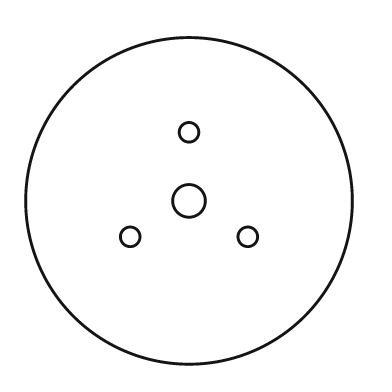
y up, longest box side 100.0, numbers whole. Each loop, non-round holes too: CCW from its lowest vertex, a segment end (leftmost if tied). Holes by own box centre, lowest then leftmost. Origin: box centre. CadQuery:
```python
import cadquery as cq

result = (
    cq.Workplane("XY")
    .moveTo(0.0, 0.0)
    .circle(50.0)
    .moveTo(-18.0, -11.0)
    .circle(3.0)
    .moveTo(18.0, -11.0)
    .circle(3.0)
    .moveTo(0.0, 0.0)
    .circle(5.0)
    .moveTo(0.0, 21.0)
    .circle(3.0)
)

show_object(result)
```